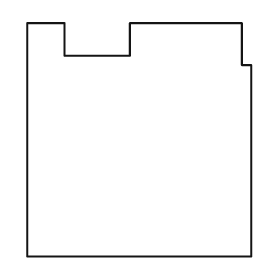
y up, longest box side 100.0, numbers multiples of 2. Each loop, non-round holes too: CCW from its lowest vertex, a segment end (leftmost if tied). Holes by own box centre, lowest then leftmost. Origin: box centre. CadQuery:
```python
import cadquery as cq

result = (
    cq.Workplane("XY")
    .moveTo(-48.0, -50.0)
    .lineTo(48.0, -50.0)
    .lineTo(48.0, 32.0)
    .lineTo(44.0, 32.0)
    .lineTo(44.0, 50.0)
    .lineTo(-4.0, 50.0)
    .lineTo(-4.0, 36.0)
    .lineTo(-32.0, 36.0)
    .lineTo(-32.0, 50.0)
    .lineTo(-48.0, 50.0)
    .close()
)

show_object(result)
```